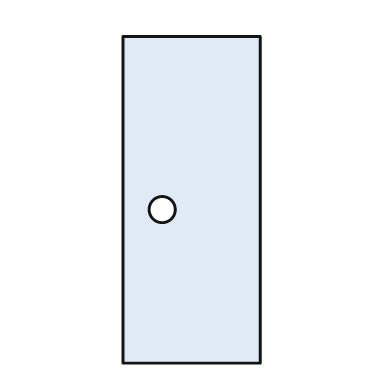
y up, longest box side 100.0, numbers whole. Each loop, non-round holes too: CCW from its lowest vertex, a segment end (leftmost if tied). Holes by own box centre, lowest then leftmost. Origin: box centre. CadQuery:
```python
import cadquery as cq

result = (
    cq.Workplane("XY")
    .moveTo(-21.0, -50.0)
    .lineTo(21.0, -50.0)
    .lineTo(21.0, 50.0)
    .lineTo(-21.0, 50.0)
    .close()
    .moveTo(-9.0, -3.0)
    .circle(4.0)
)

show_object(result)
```